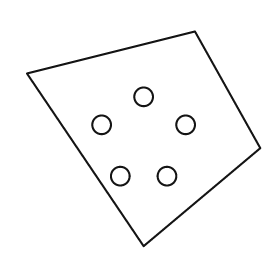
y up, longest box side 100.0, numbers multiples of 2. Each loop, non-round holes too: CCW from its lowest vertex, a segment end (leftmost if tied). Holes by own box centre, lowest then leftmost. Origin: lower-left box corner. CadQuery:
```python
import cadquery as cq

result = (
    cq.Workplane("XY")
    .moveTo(50.0, 0.0)
    .lineTo(100.0, 42.0)
    .lineTo(72.0, 92.0)
    .lineTo(0.0, 74.0)
    .close()
    .moveTo(40.0, 30.0)
    .circle(4.0)
    .moveTo(60.0, 30.0)
    .circle(4.0)
    .moveTo(32.0, 52.0)
    .circle(4.0)
    .moveTo(68.0, 52.0)
    .circle(4.0)
    .moveTo(50.0, 64.0)
    .circle(4.0)
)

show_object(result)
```